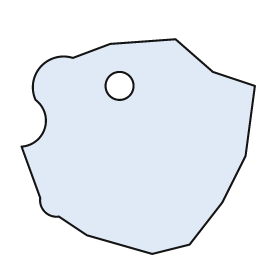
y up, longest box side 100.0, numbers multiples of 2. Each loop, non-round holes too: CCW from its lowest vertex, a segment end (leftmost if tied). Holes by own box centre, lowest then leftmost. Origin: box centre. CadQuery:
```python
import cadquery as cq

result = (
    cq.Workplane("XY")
    .moveTo(6.0, -46.0)
    .lineTo(22.0, -42.0)
    .lineTo(36.0, -24.0)
    .lineTo(46.0, -4.0)
    .lineTo(50.0, 26.0)
    .lineTo(32.0, 32.0)
    .lineTo(16.0, 46.0)
    .lineTo(-12.0, 44.0)
    .lineTo(-28.0, 38.0)
    .threePointArc((-42.0, 34.0), (-44.0, 20.0))
    .threePointArc((-40.0, 8.0), (-50.0, 0.0))
    .lineTo(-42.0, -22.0)
    .threePointArc((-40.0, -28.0), (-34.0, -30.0))
    .lineTo(-22.0, -38.0)
    .close()
    .moveTo(-8.0, 26.0)
    .circle(6.0)
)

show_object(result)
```